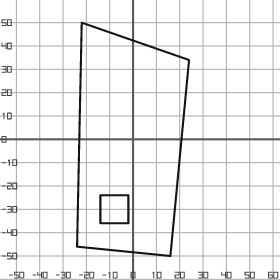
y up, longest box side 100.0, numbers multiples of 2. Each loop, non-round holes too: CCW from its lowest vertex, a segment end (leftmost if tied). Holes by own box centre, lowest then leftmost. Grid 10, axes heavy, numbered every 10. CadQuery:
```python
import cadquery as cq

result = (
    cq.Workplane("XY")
    .moveTo(16.0, -50.0)
    .lineTo(24.0, 34.0)
    .lineTo(-22.0, 50.0)
    .lineTo(-24.0, -46.0)
    .close()
    .moveTo(-14.0, -36.0)
    .lineTo(-2.0, -36.0)
    .lineTo(-2.0, -24.0)
    .lineTo(-14.0, -24.0)
    .close()
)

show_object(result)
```